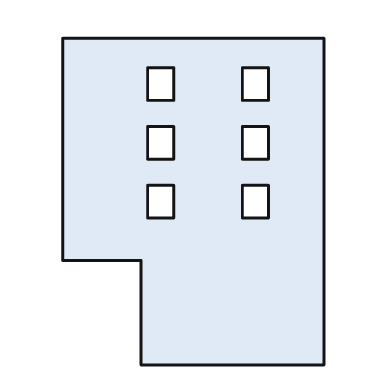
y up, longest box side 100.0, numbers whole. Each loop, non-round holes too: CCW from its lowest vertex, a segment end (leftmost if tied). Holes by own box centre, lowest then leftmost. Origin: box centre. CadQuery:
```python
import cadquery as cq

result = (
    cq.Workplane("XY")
    .moveTo(-16.0, -50.0)
    .lineTo(40.0, -50.0)
    .lineTo(40.0, 50.0)
    .lineTo(-40.0, 50.0)
    .lineTo(-40.0, -18.0)
    .lineTo(-16.0, -18.0)
    .close()
    .moveTo(-14.0, -5.0)
    .lineTo(-6.0, -5.0)
    .lineTo(-6.0, 5.0)
    .lineTo(-14.0, 5.0)
    .close()
    .moveTo(15.0, -5.0)
    .lineTo(23.0, -5.0)
    .lineTo(23.0, 5.0)
    .lineTo(15.0, 5.0)
    .close()
    .moveTo(-14.0, 13.0)
    .lineTo(-6.0, 13.0)
    .lineTo(-6.0, 23.0)
    .lineTo(-14.0, 23.0)
    .close()
    .moveTo(15.0, 13.0)
    .lineTo(23.0, 13.0)
    .lineTo(23.0, 23.0)
    .lineTo(15.0, 23.0)
    .close()
    .moveTo(-14.0, 31.0)
    .lineTo(-6.0, 31.0)
    .lineTo(-6.0, 41.0)
    .lineTo(-14.0, 41.0)
    .close()
    .moveTo(15.0, 31.0)
    .lineTo(23.0, 31.0)
    .lineTo(23.0, 41.0)
    .lineTo(15.0, 41.0)
    .close()
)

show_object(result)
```